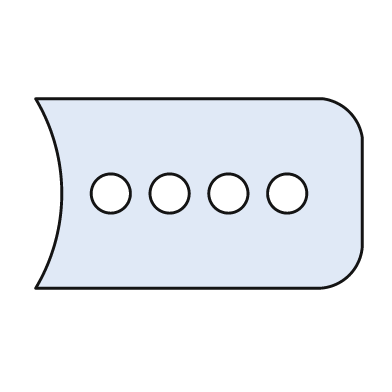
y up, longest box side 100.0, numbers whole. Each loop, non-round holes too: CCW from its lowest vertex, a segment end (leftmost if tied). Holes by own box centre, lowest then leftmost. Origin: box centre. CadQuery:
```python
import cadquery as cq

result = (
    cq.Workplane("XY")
    .moveTo(-50.0, -29.0)
    .lineTo(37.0, -29.0)
    .threePointArc((46.0, -25.0), (50.0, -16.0))
    .lineTo(50.0, 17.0)
    .threePointArc((46.0, 25.0), (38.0, 29.0))
    .lineTo(-50.0, 29.0)
    .threePointArc((-42.0, 0.0), (-50.0, -29.0))
    .close()
    .moveTo(-27.0, 0.0)
    .circle(6.0)
    .moveTo(-9.0, 0.0)
    .circle(6.0)
    .moveTo(9.0, 0.0)
    .circle(6.0)
    .moveTo(27.0, 0.0)
    .circle(6.0)
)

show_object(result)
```